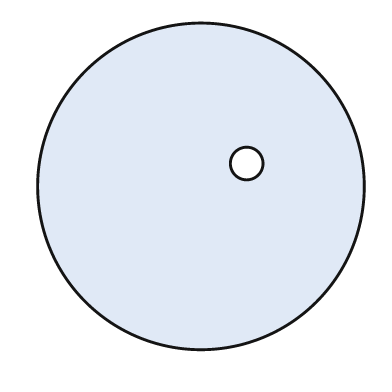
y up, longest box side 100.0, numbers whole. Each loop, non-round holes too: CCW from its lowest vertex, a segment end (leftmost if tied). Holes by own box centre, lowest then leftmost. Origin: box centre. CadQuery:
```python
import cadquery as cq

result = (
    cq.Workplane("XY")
    .moveTo(0.0, 0.0)
    .circle(50.0)
    .moveTo(14.0, 7.0)
    .circle(5.0)
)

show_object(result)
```